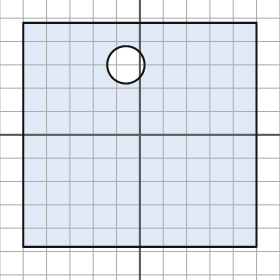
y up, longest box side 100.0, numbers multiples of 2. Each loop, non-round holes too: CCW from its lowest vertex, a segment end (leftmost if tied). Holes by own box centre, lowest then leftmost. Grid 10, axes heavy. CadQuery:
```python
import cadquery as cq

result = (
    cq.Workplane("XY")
    .moveTo(-50.0, -48.0)
    .lineTo(50.0, -48.0)
    .lineTo(50.0, 48.0)
    .lineTo(-50.0, 48.0)
    .close()
    .moveTo(-6.0, 30.0)
    .circle(8.0)
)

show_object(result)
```